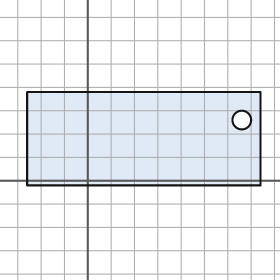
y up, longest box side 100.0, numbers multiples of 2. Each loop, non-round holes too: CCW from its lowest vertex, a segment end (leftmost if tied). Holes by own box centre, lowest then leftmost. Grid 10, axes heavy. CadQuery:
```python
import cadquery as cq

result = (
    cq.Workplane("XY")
    .moveTo(-26.0, -2.0)
    .lineTo(74.0, -2.0)
    .lineTo(74.0, 38.0)
    .lineTo(-26.0, 38.0)
    .close()
    .moveTo(66.0, 26.0)
    .circle(4.0)
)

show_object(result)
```